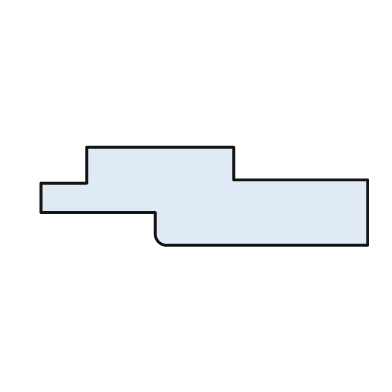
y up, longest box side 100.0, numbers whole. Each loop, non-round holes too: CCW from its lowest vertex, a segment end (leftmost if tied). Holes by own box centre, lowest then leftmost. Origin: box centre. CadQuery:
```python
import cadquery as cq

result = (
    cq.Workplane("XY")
    .moveTo(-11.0, -15.0)
    .lineTo(50.0, -15.0)
    .lineTo(50.0, 5.0)
    .lineTo(9.0, 5.0)
    .lineTo(9.0, 15.0)
    .lineTo(-36.0, 15.0)
    .lineTo(-36.0, 4.0)
    .lineTo(-50.0, 4.0)
    .lineTo(-50.0, -5.0)
    .lineTo(-15.0, -5.0)
    .lineTo(-15.0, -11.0)
    .threePointArc((-14.0, -14.0), (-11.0, -15.0))
    .close()
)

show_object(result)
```